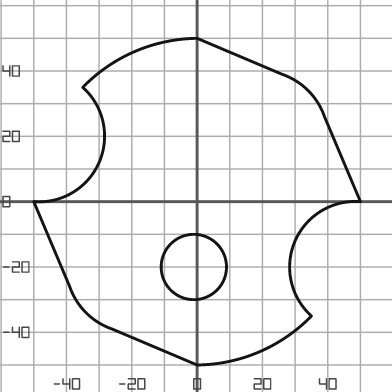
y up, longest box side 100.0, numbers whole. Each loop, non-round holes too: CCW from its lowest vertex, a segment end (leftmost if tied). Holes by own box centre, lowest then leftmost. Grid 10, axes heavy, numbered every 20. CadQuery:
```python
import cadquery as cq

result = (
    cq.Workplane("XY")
    .moveTo(0.0, -50.0)
    .threePointArc((19.0, -46.0), (35.0, -35.0))
    .threePointArc((30.0, -12.0), (50.0, 0.0))
    .lineTo(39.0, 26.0)
    .threePointArc((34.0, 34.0), (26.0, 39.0))
    .lineTo(0.0, 50.0)
    .threePointArc((-19.0, 46.0), (-35.0, 35.0))
    .threePointArc((-30.0, 12.0), (-50.0, 0.0))
    .lineTo(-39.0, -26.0)
    .threePointArc((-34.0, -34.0), (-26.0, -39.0))
    .close()
    .moveTo(-1.0, -20.0)
    .circle(10.0)
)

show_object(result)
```